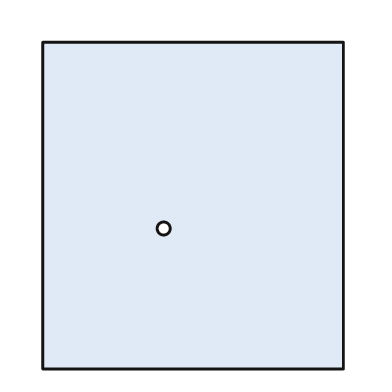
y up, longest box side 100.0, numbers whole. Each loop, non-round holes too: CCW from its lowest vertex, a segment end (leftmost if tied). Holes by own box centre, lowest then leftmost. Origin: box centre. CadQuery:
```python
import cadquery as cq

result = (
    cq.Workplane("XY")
    .moveTo(-46.0, -50.0)
    .lineTo(46.0, -50.0)
    .lineTo(46.0, 50.0)
    .lineTo(-46.0, 50.0)
    .close()
    .moveTo(-9.0, -7.0)
    .circle(2.0)
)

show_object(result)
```